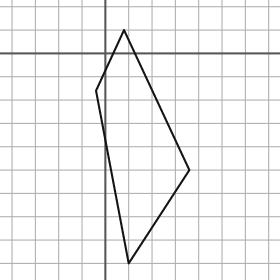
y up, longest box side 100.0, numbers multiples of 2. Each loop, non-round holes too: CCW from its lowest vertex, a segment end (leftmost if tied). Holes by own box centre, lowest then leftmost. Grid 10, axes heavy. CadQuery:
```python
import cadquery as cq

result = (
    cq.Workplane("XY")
    .moveTo(10.0, -90.0)
    .lineTo(36.0, -50.0)
    .lineTo(8.0, 10.0)
    .lineTo(-4.0, -16.0)
    .close()
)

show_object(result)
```